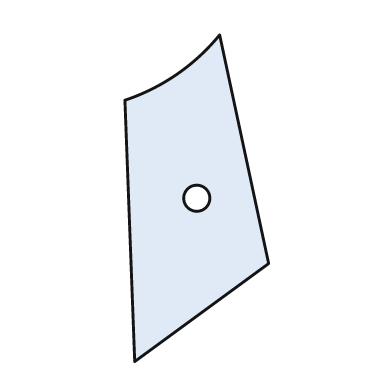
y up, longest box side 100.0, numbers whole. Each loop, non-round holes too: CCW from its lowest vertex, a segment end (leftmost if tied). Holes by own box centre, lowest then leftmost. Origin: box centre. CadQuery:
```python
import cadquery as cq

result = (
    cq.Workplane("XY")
    .moveTo(-19.0, -50.0)
    .lineTo(22.0, -20.0)
    .lineTo(7.0, 50.0)
    .threePointArc((-6.0, 38.0), (-22.0, 30.0))
    .close()
    .moveTo(0.0, 0.0)
    .circle(4.0)
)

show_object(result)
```